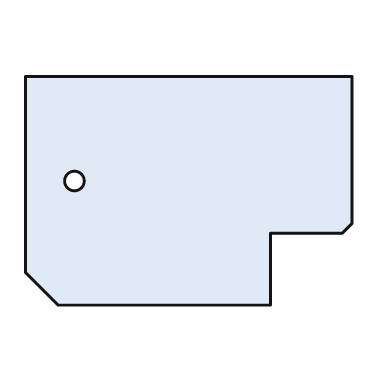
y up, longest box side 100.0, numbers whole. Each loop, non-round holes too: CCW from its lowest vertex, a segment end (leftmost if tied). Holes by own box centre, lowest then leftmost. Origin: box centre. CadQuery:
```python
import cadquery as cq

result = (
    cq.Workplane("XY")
    .moveTo(-40.0, -35.0)
    .lineTo(25.0, -35.0)
    .lineTo(25.0, -13.0)
    .lineTo(47.0, -13.0)
    .lineTo(50.0, -10.0)
    .lineTo(50.0, 35.0)
    .lineTo(-50.0, 35.0)
    .lineTo(-50.0, -25.0)
    .close()
    .moveTo(-35.0, 3.0)
    .circle(3.0)
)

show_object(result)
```